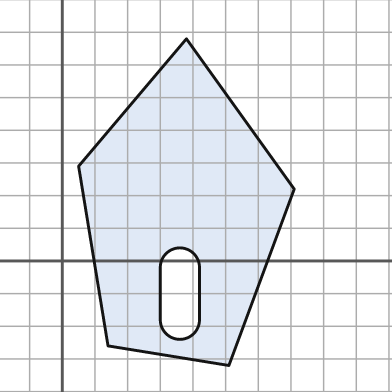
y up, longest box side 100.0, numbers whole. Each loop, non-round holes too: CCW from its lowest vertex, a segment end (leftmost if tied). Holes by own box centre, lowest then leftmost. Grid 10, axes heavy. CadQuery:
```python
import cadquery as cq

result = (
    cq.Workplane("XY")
    .moveTo(51.0, -32.0)
    .lineTo(71.0, 22.0)
    .lineTo(38.0, 68.0)
    .lineTo(5.0, 29.0)
    .lineTo(14.0, -26.0)
    .close()
    .moveTo(30.0, -18.0)
    .threePointArc((36.0, -24.0), (42.0, -18.0))
    .lineTo(42.0, -2.0)
    .threePointArc((36.0, 4.0), (30.0, -2.0))
    .close()
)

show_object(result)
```